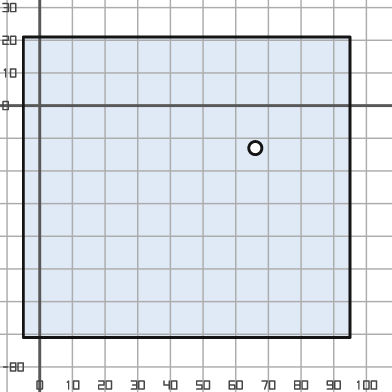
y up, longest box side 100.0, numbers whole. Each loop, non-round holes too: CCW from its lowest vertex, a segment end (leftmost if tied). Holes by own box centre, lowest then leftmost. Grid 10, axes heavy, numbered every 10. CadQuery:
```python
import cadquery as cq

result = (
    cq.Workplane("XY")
    .moveTo(-5.0, -71.0)
    .lineTo(95.0, -71.0)
    .lineTo(95.0, 21.0)
    .lineTo(-5.0, 21.0)
    .close()
    .moveTo(66.0, -13.0)
    .circle(2.0)
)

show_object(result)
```